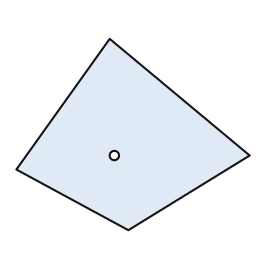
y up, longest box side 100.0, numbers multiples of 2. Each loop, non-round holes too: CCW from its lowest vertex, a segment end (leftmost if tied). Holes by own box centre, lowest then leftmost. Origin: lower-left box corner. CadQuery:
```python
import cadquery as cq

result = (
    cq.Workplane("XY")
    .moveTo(48.0, 0.0)
    .lineTo(100.0, 32.0)
    .lineTo(40.0, 82.0)
    .lineTo(0.0, 26.0)
    .close()
    .moveTo(42.0, 32.0)
    .circle(2.0)
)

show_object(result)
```